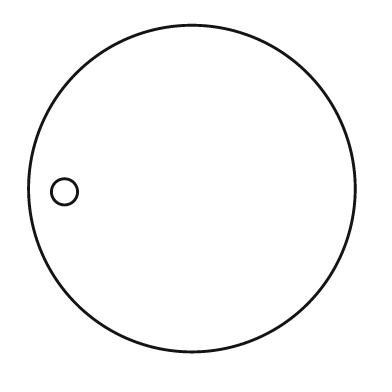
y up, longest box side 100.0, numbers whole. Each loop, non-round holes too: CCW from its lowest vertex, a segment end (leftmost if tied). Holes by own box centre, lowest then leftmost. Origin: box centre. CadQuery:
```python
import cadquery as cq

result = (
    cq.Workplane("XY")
    .moveTo(0.0, 0.0)
    .circle(50.0)
    .moveTo(-39.0, -1.0)
    .circle(4.0)
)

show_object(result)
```